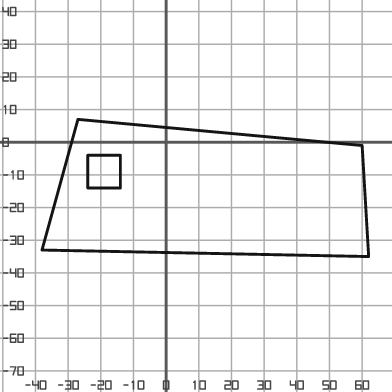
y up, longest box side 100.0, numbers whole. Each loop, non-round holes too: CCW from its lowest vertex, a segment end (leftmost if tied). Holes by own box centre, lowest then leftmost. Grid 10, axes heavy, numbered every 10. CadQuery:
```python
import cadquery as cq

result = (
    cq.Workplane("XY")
    .moveTo(62.0, -35.0)
    .lineTo(60.0, -1.0)
    .lineTo(-27.0, 7.0)
    .lineTo(-38.0, -33.0)
    .close()
    .moveTo(-24.0, -14.0)
    .lineTo(-14.0, -14.0)
    .lineTo(-14.0, -4.0)
    .lineTo(-24.0, -4.0)
    .close()
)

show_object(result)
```